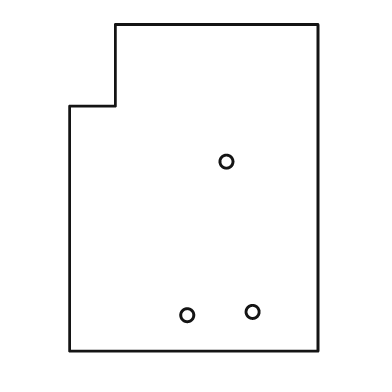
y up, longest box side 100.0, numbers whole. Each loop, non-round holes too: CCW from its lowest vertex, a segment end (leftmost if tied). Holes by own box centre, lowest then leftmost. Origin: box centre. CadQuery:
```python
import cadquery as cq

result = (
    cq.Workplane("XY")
    .moveTo(-38.0, -50.0)
    .lineTo(38.0, -50.0)
    .lineTo(38.0, 50.0)
    .lineTo(-24.0, 50.0)
    .lineTo(-24.0, 25.0)
    .lineTo(-38.0, 25.0)
    .close()
    .moveTo(-2.0, -39.0)
    .circle(2.0)
    .moveTo(18.0, -38.0)
    .circle(2.0)
    .moveTo(10.0, 8.0)
    .circle(2.0)
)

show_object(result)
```